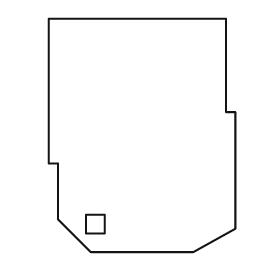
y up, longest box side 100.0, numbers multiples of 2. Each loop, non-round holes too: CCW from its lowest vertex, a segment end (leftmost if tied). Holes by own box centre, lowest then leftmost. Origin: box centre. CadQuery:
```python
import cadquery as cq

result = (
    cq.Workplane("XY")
    .moveTo(-22.0, -50.0)
    .lineTo(22.0, -50.0)
    .lineTo(40.0, -40.0)
    .lineTo(40.0, 10.0)
    .lineTo(36.0, 10.0)
    .lineTo(36.0, 50.0)
    .lineTo(-40.0, 50.0)
    .lineTo(-40.0, -12.0)
    .lineTo(-36.0, -12.0)
    .lineTo(-36.0, -36.0)
    .close()
    .moveTo(-24.0, -42.0)
    .lineTo(-16.0, -42.0)
    .lineTo(-16.0, -34.0)
    .lineTo(-24.0, -34.0)
    .close()
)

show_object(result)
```